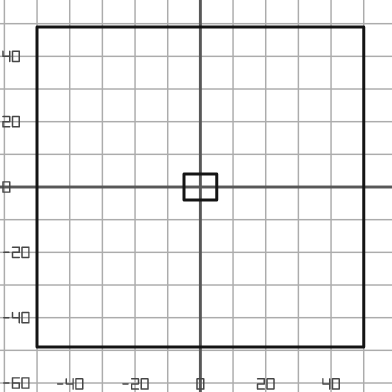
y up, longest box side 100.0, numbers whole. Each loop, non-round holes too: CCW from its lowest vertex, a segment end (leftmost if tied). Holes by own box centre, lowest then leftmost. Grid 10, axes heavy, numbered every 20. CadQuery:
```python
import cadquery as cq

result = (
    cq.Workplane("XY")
    .moveTo(-50.0, -49.0)
    .lineTo(50.0, -49.0)
    .lineTo(50.0, 49.0)
    .lineTo(-50.0, 49.0)
    .close()
    .moveTo(-5.0, -4.0)
    .lineTo(5.0, -4.0)
    .lineTo(5.0, 4.0)
    .lineTo(-5.0, 4.0)
    .close()
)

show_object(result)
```